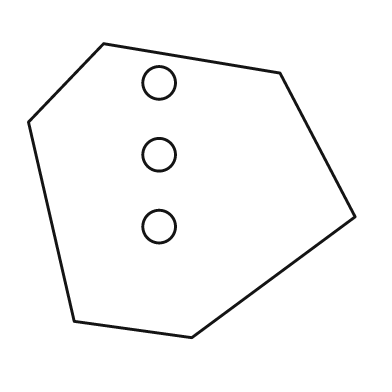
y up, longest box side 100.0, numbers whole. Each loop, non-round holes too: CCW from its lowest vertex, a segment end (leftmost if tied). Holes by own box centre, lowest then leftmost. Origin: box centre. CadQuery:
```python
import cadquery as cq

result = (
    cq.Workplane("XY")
    .moveTo(0.0, -45.0)
    .lineTo(50.0, -8.0)
    .lineTo(27.0, 36.0)
    .lineTo(-27.0, 45.0)
    .lineTo(-50.0, 21.0)
    .lineTo(-36.0, -40.0)
    .close()
    .moveTo(-10.0, -11.0)
    .circle(5.0)
    .moveTo(-10.0, 11.0)
    .circle(5.0)
    .moveTo(-10.0, 33.0)
    .circle(5.0)
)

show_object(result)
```